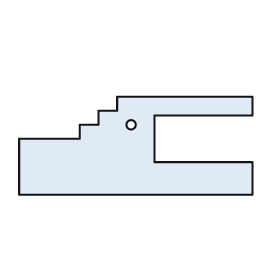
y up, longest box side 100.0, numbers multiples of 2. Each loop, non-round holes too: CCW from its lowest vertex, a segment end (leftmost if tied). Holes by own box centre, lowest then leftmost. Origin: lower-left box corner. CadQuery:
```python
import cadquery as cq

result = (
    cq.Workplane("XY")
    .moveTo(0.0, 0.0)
    .lineTo(100.0, 0.0)
    .lineTo(100.0, 14.0)
    .lineTo(58.0, 14.0)
    .lineTo(58.0, 34.0)
    .lineTo(100.0, 34.0)
    .lineTo(100.0, 42.0)
    .lineTo(42.0, 42.0)
    .lineTo(42.0, 36.0)
    .lineTo(34.0, 36.0)
    .lineTo(34.0, 30.0)
    .lineTo(26.0, 30.0)
    .lineTo(26.0, 24.0)
    .lineTo(0.0, 24.0)
    .close()
    .moveTo(48.0, 30.0)
    .circle(2.0)
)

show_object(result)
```